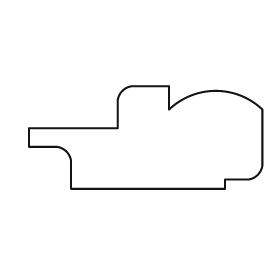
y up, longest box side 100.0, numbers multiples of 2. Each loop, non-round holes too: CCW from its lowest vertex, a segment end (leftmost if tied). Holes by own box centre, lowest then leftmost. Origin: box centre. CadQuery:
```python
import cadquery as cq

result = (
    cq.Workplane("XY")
    .moveTo(-32.0, -22.0)
    .lineTo(34.0, -22.0)
    .lineTo(34.0, -18.0)
    .lineTo(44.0, -18.0)
    .threePointArc((48.0, -16.0), (50.0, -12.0))
    .lineTo(50.0, 12.0)
    .threePointArc((30.0, 20.0), (10.0, 12.0))
    .lineTo(10.0, 22.0)
    .lineTo(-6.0, 22.0)
    .threePointArc((-10.0, 20.0), (-12.0, 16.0))
    .lineTo(-12.0, 4.0)
    .lineTo(-50.0, 4.0)
    .lineTo(-50.0, -4.0)
    .lineTo(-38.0, -4.0)
    .threePointArc((-34.0, -6.0), (-32.0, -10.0))
    .close()
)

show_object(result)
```